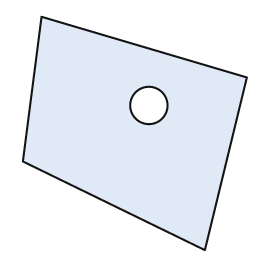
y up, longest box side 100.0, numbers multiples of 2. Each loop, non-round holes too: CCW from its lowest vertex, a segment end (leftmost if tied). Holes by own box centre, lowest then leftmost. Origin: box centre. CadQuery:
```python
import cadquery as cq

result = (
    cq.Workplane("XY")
    .moveTo(30.0, -50.0)
    .lineTo(48.0, 24.0)
    .lineTo(-40.0, 50.0)
    .lineTo(-48.0, -12.0)
    .close()
    .moveTo(6.0, 12.0)
    .circle(8.0)
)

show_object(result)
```